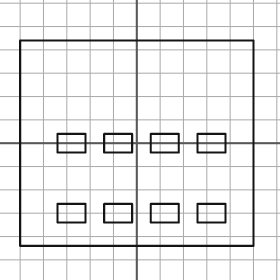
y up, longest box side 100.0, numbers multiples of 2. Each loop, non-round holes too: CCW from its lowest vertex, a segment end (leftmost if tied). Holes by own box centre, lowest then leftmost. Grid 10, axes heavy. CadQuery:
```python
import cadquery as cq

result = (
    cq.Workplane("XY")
    .moveTo(-50.0, -44.0)
    .lineTo(50.0, -44.0)
    .lineTo(50.0, 44.0)
    .lineTo(-50.0, 44.0)
    .close()
    .moveTo(-34.0, -34.0)
    .lineTo(-22.0, -34.0)
    .lineTo(-22.0, -26.0)
    .lineTo(-34.0, -26.0)
    .close()
    .moveTo(-14.0, -34.0)
    .lineTo(-2.0, -34.0)
    .lineTo(-2.0, -26.0)
    .lineTo(-14.0, -26.0)
    .close()
    .moveTo(6.0, -34.0)
    .lineTo(18.0, -34.0)
    .lineTo(18.0, -26.0)
    .lineTo(6.0, -26.0)
    .close()
    .moveTo(26.0, -34.0)
    .lineTo(38.0, -34.0)
    .lineTo(38.0, -26.0)
    .lineTo(26.0, -26.0)
    .close()
    .moveTo(-34.0, -4.0)
    .lineTo(-22.0, -4.0)
    .lineTo(-22.0, 4.0)
    .lineTo(-34.0, 4.0)
    .close()
    .moveTo(-14.0, -4.0)
    .lineTo(-2.0, -4.0)
    .lineTo(-2.0, 4.0)
    .lineTo(-14.0, 4.0)
    .close()
    .moveTo(6.0, -4.0)
    .lineTo(18.0, -4.0)
    .lineTo(18.0, 4.0)
    .lineTo(6.0, 4.0)
    .close()
    .moveTo(26.0, -4.0)
    .lineTo(38.0, -4.0)
    .lineTo(38.0, 4.0)
    .lineTo(26.0, 4.0)
    .close()
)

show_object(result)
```